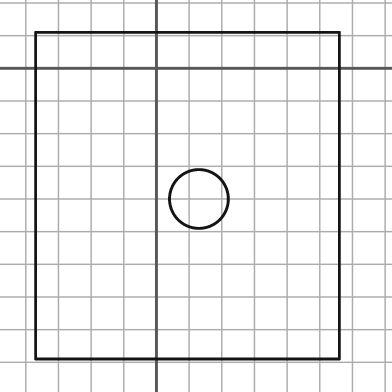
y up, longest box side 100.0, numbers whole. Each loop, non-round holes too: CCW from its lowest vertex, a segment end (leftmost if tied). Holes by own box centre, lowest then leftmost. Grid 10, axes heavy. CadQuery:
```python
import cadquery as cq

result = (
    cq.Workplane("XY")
    .moveTo(-37.0, -89.0)
    .lineTo(56.0, -89.0)
    .lineTo(56.0, 11.0)
    .lineTo(-37.0, 11.0)
    .close()
    .moveTo(13.0, -40.0)
    .circle(9.0)
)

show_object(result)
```